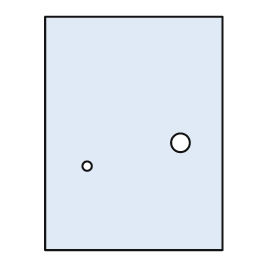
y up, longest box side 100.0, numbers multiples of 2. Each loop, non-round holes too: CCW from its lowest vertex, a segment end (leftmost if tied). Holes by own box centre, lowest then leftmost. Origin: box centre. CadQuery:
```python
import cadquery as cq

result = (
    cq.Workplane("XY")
    .moveTo(-38.0, -50.0)
    .lineTo(38.0, -50.0)
    .lineTo(38.0, 50.0)
    .lineTo(-38.0, 50.0)
    .close()
    .moveTo(-20.0, -14.0)
    .circle(2.0)
    .moveTo(20.0, -4.0)
    .circle(4.0)
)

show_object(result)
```